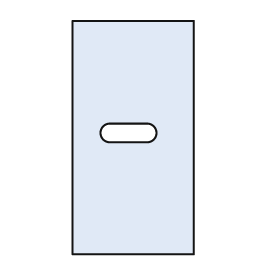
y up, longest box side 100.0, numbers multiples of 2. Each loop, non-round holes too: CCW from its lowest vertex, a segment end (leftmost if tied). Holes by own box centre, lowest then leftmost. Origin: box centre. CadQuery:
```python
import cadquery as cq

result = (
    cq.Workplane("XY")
    .moveTo(-26.0, -50.0)
    .lineTo(26.0, -50.0)
    .lineTo(26.0, 50.0)
    .lineTo(-26.0, 50.0)
    .close()
    .moveTo(-10.0, -2.0)
    .lineTo(6.0, -2.0)
    .threePointArc((10.0, 2.0), (6.0, 6.0))
    .lineTo(-10.0, 6.0)
    .threePointArc((-14.0, 2.0), (-10.0, -2.0))
    .close()
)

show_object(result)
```